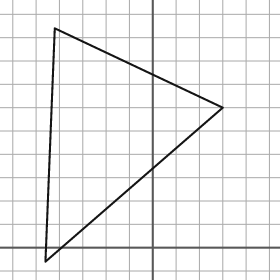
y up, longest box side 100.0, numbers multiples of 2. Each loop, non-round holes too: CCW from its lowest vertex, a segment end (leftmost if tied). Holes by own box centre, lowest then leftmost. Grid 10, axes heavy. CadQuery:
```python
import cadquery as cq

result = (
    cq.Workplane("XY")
    .moveTo(-46.0, -6.0)
    .lineTo(30.0, 60.0)
    .lineTo(-42.0, 94.0)
    .close()
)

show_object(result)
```